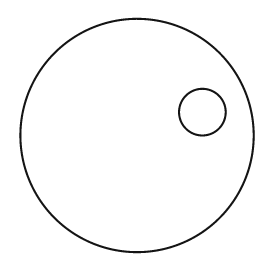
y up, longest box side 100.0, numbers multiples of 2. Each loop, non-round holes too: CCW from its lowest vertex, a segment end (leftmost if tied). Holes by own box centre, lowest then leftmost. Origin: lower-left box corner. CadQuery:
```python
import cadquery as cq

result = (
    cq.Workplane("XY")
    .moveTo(50.0, 50.0)
    .circle(50.0)
    .moveTo(78.0, 60.0)
    .circle(10.0)
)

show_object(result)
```